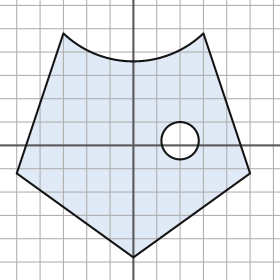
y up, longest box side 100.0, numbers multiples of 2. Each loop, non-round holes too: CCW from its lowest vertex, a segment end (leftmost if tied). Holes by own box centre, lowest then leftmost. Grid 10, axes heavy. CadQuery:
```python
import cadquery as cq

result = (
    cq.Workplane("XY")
    .moveTo(0.0, -48.0)
    .lineTo(50.0, -12.0)
    .lineTo(30.0, 48.0)
    .threePointArc((0.0, 36.0), (-30.0, 48.0))
    .lineTo(-50.0, -12.0)
    .close()
    .moveTo(20.0, 2.0)
    .circle(8.0)
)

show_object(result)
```